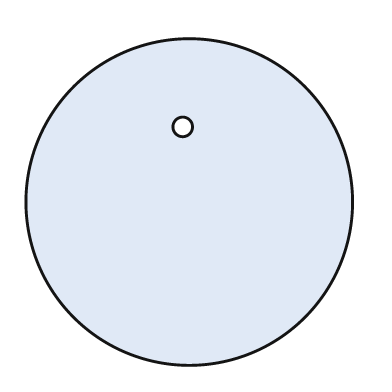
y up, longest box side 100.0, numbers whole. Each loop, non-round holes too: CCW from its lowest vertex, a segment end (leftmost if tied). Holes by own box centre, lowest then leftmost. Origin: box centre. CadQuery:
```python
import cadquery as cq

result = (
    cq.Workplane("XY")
    .moveTo(0.0, 0.0)
    .circle(50.0)
    .moveTo(-2.0, 23.0)
    .circle(3.0)
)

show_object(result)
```